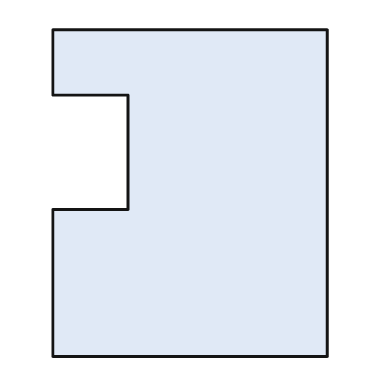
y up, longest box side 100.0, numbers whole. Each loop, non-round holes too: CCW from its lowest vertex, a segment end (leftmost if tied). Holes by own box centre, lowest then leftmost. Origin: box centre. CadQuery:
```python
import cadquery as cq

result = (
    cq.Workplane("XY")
    .moveTo(-42.0, -50.0)
    .lineTo(42.0, -50.0)
    .lineTo(42.0, 50.0)
    .lineTo(-42.0, 50.0)
    .lineTo(-42.0, 30.0)
    .lineTo(-19.0, 30.0)
    .lineTo(-19.0, -5.0)
    .lineTo(-42.0, -5.0)
    .close()
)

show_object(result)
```